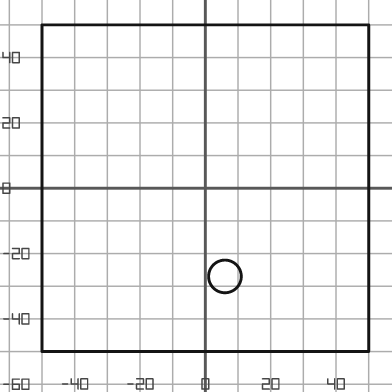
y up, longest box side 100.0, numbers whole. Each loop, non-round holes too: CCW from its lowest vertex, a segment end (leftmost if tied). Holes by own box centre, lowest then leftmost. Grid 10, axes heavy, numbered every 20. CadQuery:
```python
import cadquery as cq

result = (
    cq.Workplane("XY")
    .moveTo(-50.0, -50.0)
    .lineTo(50.0, -50.0)
    .lineTo(50.0, 50.0)
    .lineTo(-50.0, 50.0)
    .close()
    .moveTo(6.0, -27.0)
    .circle(5.0)
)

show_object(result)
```